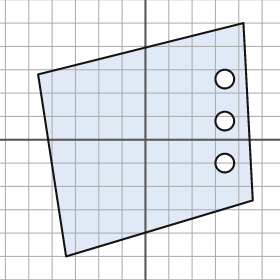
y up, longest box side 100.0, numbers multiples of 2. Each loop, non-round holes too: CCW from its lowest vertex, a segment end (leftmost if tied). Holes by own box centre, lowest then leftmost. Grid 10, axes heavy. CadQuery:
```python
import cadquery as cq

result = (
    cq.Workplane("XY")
    .moveTo(-34.0, -50.0)
    .lineTo(46.0, -26.0)
    .lineTo(42.0, 50.0)
    .lineTo(-46.0, 28.0)
    .close()
    .moveTo(34.0, -10.0)
    .circle(4.0)
    .moveTo(34.0, 8.0)
    .circle(4.0)
    .moveTo(34.0, 26.0)
    .circle(4.0)
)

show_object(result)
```